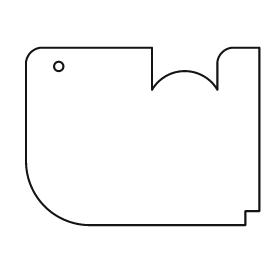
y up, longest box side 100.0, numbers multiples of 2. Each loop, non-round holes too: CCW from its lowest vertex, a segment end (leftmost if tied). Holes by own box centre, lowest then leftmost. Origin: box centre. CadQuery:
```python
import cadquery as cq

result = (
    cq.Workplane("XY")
    .moveTo(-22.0, -38.0)
    .lineTo(44.0, -38.0)
    .lineTo(44.0, -32.0)
    .lineTo(50.0, -32.0)
    .lineTo(50.0, 38.0)
    .lineTo(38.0, 38.0)
    .threePointArc((34.0, 36.0), (32.0, 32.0))
    .lineTo(32.0, 20.0)
    .threePointArc((18.0, 28.0), (4.0, 20.0))
    .lineTo(4.0, 38.0)
    .lineTo(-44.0, 38.0)
    .threePointArc((-48.0, 36.0), (-50.0, 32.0))
    .lineTo(-50.0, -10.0)
    .threePointArc((-42.0, -30.0), (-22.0, -38.0))
    .close()
    .moveTo(-36.0, 30.0)
    .circle(2.0)
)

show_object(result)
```